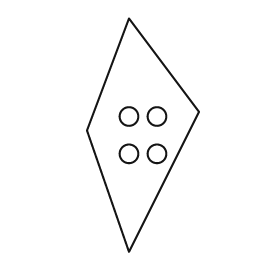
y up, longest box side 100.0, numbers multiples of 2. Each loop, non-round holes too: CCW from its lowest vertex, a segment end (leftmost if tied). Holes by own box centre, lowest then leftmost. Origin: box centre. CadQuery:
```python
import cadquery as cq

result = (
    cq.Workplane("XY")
    .moveTo(-6.0, -50.0)
    .lineTo(24.0, 10.0)
    .lineTo(-6.0, 50.0)
    .lineTo(-24.0, 2.0)
    .close()
    .moveTo(-6.0, -8.0)
    .circle(4.0)
    .moveTo(6.0, -8.0)
    .circle(4.0)
    .moveTo(-6.0, 8.0)
    .circle(4.0)
    .moveTo(6.0, 8.0)
    .circle(4.0)
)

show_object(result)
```